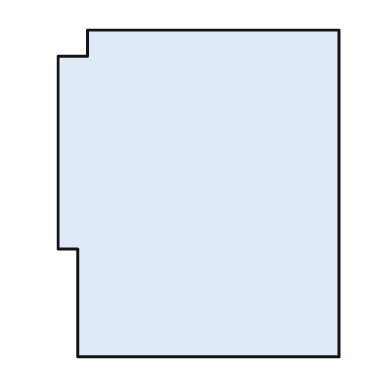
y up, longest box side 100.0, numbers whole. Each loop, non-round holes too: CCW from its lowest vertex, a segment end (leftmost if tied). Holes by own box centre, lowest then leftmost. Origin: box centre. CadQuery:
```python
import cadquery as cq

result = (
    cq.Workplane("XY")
    .moveTo(-37.0, -50.0)
    .lineTo(43.0, -50.0)
    .lineTo(43.0, 50.0)
    .lineTo(-34.0, 50.0)
    .lineTo(-34.0, 42.0)
    .lineTo(-43.0, 42.0)
    .lineTo(-43.0, -17.0)
    .lineTo(-37.0, -17.0)
    .close()
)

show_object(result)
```